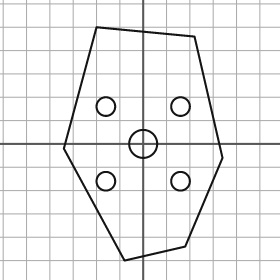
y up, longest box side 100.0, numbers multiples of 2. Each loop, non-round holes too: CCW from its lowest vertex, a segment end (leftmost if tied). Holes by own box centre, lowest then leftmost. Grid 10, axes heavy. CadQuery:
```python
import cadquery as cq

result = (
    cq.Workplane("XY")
    .moveTo(-8.0, -50.0)
    .lineTo(18.0, -44.0)
    .lineTo(34.0, -6.0)
    .lineTo(22.0, 46.0)
    .lineTo(-20.0, 50.0)
    .lineTo(-34.0, -2.0)
    .close()
    .moveTo(-16.0, -16.0)
    .circle(4.0)
    .moveTo(16.0, -16.0)
    .circle(4.0)
    .moveTo(0.0, 0.0)
    .circle(6.0)
    .moveTo(-16.0, 16.0)
    .circle(4.0)
    .moveTo(16.0, 16.0)
    .circle(4.0)
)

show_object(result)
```